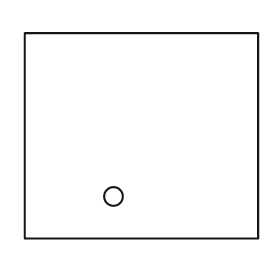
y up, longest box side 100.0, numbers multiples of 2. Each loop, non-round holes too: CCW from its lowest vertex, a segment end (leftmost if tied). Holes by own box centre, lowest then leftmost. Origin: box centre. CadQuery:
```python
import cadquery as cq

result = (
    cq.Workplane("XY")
    .moveTo(-50.0, -44.0)
    .lineTo(50.0, -44.0)
    .lineTo(50.0, 44.0)
    .lineTo(-50.0, 44.0)
    .close()
    .moveTo(-12.0, -26.0)
    .circle(4.0)
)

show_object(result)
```